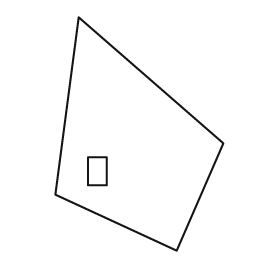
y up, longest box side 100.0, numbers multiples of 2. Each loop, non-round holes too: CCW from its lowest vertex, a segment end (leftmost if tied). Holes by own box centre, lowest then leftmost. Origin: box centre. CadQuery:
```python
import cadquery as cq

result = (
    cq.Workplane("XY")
    .moveTo(16.0, -50.0)
    .lineTo(36.0, -4.0)
    .lineTo(-26.0, 50.0)
    .lineTo(-36.0, -26.0)
    .close()
    .moveTo(-22.0, -22.0)
    .lineTo(-14.0, -22.0)
    .lineTo(-14.0, -10.0)
    .lineTo(-22.0, -10.0)
    .close()
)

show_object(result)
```